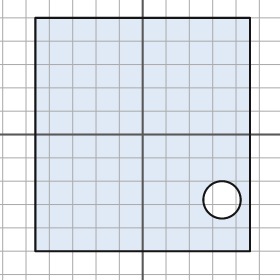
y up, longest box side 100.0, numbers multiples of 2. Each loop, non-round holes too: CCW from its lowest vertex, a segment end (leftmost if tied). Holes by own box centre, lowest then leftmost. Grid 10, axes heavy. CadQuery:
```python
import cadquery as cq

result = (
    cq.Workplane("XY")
    .moveTo(-46.0, -50.0)
    .lineTo(46.0, -50.0)
    .lineTo(46.0, 50.0)
    .lineTo(-46.0, 50.0)
    .close()
    .moveTo(34.0, -28.0)
    .circle(8.0)
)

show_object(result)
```